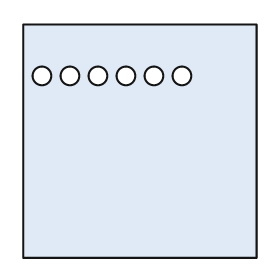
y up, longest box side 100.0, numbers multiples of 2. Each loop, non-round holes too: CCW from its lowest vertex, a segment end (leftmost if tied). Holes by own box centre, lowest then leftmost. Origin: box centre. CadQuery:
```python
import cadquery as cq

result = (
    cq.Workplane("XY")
    .moveTo(-50.0, -50.0)
    .lineTo(50.0, -50.0)
    .lineTo(50.0, 50.0)
    .lineTo(-50.0, 50.0)
    .close()
    .moveTo(-42.0, 28.0)
    .circle(4.0)
    .moveTo(-30.0, 28.0)
    .circle(4.0)
    .moveTo(-18.0, 28.0)
    .circle(4.0)
    .moveTo(-6.0, 28.0)
    .circle(4.0)
    .moveTo(6.0, 28.0)
    .circle(4.0)
    .moveTo(18.0, 28.0)
    .circle(4.0)
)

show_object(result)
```